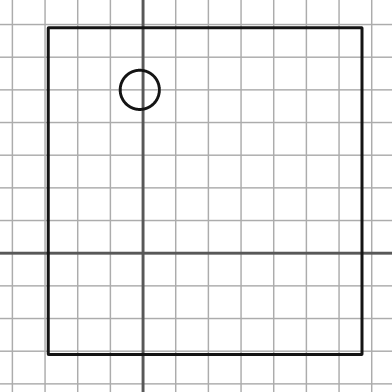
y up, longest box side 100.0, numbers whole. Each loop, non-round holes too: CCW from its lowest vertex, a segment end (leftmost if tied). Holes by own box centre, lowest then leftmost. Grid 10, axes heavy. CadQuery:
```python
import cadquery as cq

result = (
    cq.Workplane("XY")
    .moveTo(-29.0, -31.0)
    .lineTo(67.0, -31.0)
    .lineTo(67.0, 69.0)
    .lineTo(-29.0, 69.0)
    .close()
    .moveTo(-1.0, 50.0)
    .circle(6.0)
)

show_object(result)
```